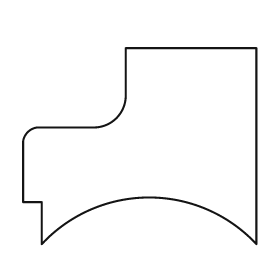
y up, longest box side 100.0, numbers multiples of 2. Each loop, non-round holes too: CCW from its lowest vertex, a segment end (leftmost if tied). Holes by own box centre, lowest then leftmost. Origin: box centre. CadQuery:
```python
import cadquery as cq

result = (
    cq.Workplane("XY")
    .moveTo(-42.0, -42.0)
    .threePointArc((4.0, -22.0), (50.0, -42.0))
    .lineTo(50.0, 42.0)
    .lineTo(-6.0, 42.0)
    .lineTo(-6.0, 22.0)
    .threePointArc((-10.0, 12.0), (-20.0, 8.0))
    .lineTo(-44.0, 8.0)
    .threePointArc((-48.0, 6.0), (-50.0, 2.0))
    .lineTo(-50.0, -24.0)
    .lineTo(-42.0, -24.0)
    .close()
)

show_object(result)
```